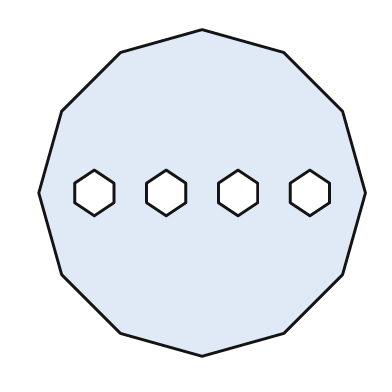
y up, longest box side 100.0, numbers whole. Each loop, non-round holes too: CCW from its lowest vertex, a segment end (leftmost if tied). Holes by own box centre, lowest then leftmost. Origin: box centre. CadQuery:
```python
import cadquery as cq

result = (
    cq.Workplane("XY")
    .moveTo(0.0, -50.0)
    .lineTo(25.0, -43.0)
    .lineTo(43.0, -25.0)
    .lineTo(50.0, 0.0)
    .lineTo(43.0, 25.0)
    .lineTo(25.0, 43.0)
    .lineTo(0.0, 50.0)
    .lineTo(-25.0, 43.0)
    .lineTo(-43.0, 25.0)
    .lineTo(-50.0, 0.0)
    .lineTo(-43.0, -25.0)
    .lineTo(-25.0, -43.0)
    .close()
    .moveTo(-33.0, -7.0)
    .lineTo(-27.0, -3.0)
    .lineTo(-27.0, 3.0)
    .lineTo(-33.0, 7.0)
    .lineTo(-39.0, 3.0)
    .lineTo(-39.0, -3.0)
    .close()
    .moveTo(-11.0, -7.0)
    .lineTo(-5.0, -3.0)
    .lineTo(-5.0, 3.0)
    .lineTo(-11.0, 7.0)
    .lineTo(-17.0, 3.0)
    .lineTo(-17.0, -3.0)
    .close()
    .moveTo(11.0, -7.0)
    .lineTo(17.0, -3.0)
    .lineTo(17.0, 3.0)
    .lineTo(11.0, 7.0)
    .lineTo(5.0, 3.0)
    .lineTo(5.0, -3.0)
    .close()
    .moveTo(33.0, -7.0)
    .lineTo(39.0, -3.0)
    .lineTo(39.0, 3.0)
    .lineTo(33.0, 7.0)
    .lineTo(27.0, 3.0)
    .lineTo(27.0, -3.0)
    .close()
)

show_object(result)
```